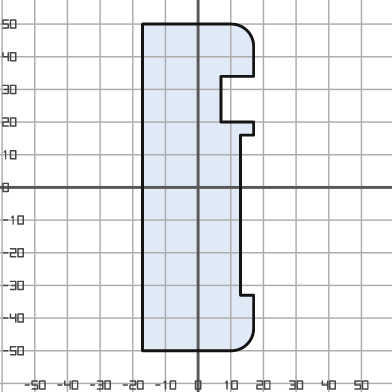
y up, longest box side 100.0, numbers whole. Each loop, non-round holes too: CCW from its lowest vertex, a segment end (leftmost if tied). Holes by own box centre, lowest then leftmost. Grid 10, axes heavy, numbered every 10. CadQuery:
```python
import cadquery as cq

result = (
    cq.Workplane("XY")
    .moveTo(-17.0, -50.0)
    .lineTo(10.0, -50.0)
    .threePointArc((15.0, -48.0), (17.0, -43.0))
    .lineTo(17.0, -33.0)
    .lineTo(13.0, -33.0)
    .lineTo(13.0, 16.0)
    .lineTo(17.0, 16.0)
    .lineTo(17.0, 20.0)
    .lineTo(7.0, 20.0)
    .lineTo(7.0, 34.0)
    .lineTo(17.0, 34.0)
    .lineTo(17.0, 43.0)
    .threePointArc((15.0, 48.0), (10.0, 50.0))
    .lineTo(-17.0, 50.0)
    .close()
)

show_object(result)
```